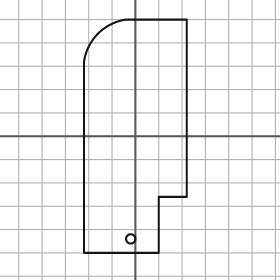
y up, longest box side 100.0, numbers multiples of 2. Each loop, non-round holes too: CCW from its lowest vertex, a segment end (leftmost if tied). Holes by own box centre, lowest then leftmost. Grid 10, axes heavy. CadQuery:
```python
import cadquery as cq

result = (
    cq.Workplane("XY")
    .moveTo(-22.0, -50.0)
    .lineTo(10.0, -50.0)
    .lineTo(10.0, -26.0)
    .lineTo(22.0, -26.0)
    .lineTo(22.0, 50.0)
    .lineTo(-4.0, 50.0)
    .threePointArc((-16.0, 44.0), (-22.0, 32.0))
    .close()
    .moveTo(-2.0, -44.0)
    .circle(2.0)
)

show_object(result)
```